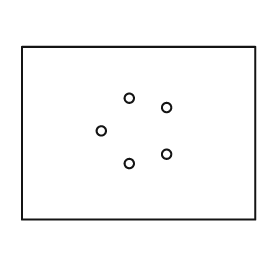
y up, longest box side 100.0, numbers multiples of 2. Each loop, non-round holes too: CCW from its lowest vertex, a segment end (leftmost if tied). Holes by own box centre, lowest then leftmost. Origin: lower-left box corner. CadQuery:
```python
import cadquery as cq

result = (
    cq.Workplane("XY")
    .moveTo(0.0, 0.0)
    .lineTo(100.0, 0.0)
    .lineTo(100.0, 74.0)
    .lineTo(0.0, 74.0)
    .close()
    .moveTo(46.0, 24.0)
    .circle(2.0)
    .moveTo(62.0, 28.0)
    .circle(2.0)
    .moveTo(34.0, 38.0)
    .circle(2.0)
    .moveTo(62.0, 48.0)
    .circle(2.0)
    .moveTo(46.0, 52.0)
    .circle(2.0)
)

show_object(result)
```